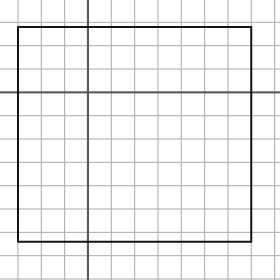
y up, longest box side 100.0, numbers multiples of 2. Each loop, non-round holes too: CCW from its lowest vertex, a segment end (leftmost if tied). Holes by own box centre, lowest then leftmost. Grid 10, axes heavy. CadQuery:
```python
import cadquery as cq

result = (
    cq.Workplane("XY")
    .moveTo(-30.0, -64.0)
    .lineTo(70.0, -64.0)
    .lineTo(70.0, 28.0)
    .lineTo(-30.0, 28.0)
    .close()
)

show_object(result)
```